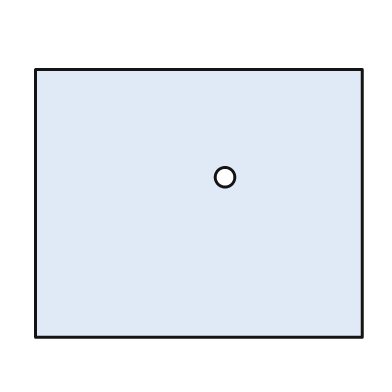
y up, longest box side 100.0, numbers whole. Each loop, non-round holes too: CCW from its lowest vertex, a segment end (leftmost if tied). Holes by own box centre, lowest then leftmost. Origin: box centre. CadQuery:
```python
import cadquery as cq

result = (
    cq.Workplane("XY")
    .moveTo(-50.0, -41.0)
    .lineTo(50.0, -41.0)
    .lineTo(50.0, 41.0)
    .lineTo(-50.0, 41.0)
    .close()
    .moveTo(8.0, 8.0)
    .circle(3.0)
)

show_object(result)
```